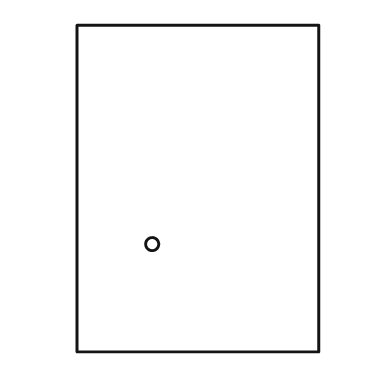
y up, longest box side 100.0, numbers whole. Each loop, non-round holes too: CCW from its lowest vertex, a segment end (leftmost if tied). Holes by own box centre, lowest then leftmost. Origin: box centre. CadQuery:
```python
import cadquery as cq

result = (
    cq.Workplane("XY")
    .moveTo(-37.0, -50.0)
    .lineTo(37.0, -50.0)
    .lineTo(37.0, 50.0)
    .lineTo(-37.0, 50.0)
    .close()
    .moveTo(-14.0, -17.0)
    .circle(2.0)
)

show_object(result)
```